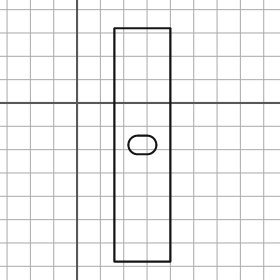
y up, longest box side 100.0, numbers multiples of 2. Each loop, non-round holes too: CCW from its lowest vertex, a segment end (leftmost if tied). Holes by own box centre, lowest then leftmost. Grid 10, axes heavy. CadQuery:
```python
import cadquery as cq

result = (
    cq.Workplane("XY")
    .moveTo(16.0, -68.0)
    .lineTo(40.0, -68.0)
    .lineTo(40.0, 32.0)
    .lineTo(16.0, 32.0)
    .close()
    .moveTo(26.0, -22.0)
    .lineTo(30.0, -22.0)
    .threePointArc((34.0, -18.0), (30.0, -14.0))
    .lineTo(26.0, -14.0)
    .threePointArc((22.0, -18.0), (26.0, -22.0))
    .close()
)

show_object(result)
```